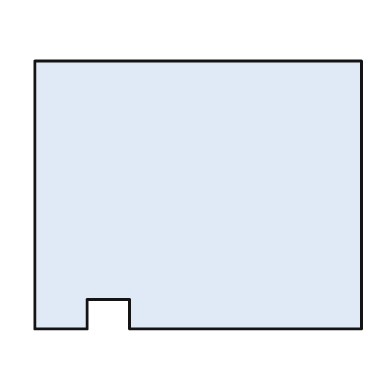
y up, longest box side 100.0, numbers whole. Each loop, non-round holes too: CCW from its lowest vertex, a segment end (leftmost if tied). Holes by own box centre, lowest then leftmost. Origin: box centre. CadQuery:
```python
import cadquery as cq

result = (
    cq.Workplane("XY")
    .moveTo(-50.0, -41.0)
    .lineTo(-34.0, -41.0)
    .lineTo(-34.0, -32.0)
    .lineTo(-21.0, -32.0)
    .lineTo(-21.0, -41.0)
    .lineTo(50.0, -41.0)
    .lineTo(50.0, 41.0)
    .lineTo(-50.0, 41.0)
    .close()
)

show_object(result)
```